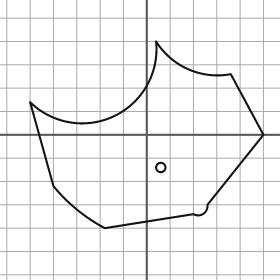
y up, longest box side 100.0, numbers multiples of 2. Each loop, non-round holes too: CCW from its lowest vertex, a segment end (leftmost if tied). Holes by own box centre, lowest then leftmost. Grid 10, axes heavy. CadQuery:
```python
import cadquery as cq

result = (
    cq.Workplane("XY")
    .moveTo(-18.0, -40.0)
    .lineTo(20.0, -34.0)
    .threePointArc((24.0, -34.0), (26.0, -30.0))
    .lineTo(50.0, 0.0)
    .lineTo(36.0, 26.0)
    .threePointArc((18.0, 28.0), (4.0, 40.0))
    .threePointArc((-14.0, 8.0), (-50.0, 14.0))
    .lineTo(-40.0, -22.0)
    .threePointArc((-30.0, -32.0), (-18.0, -40.0))
    .close()
    .moveTo(6.0, -14.0)
    .circle(2.0)
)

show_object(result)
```